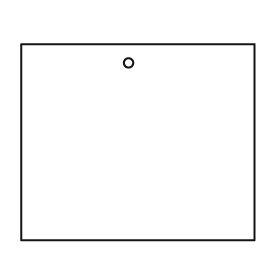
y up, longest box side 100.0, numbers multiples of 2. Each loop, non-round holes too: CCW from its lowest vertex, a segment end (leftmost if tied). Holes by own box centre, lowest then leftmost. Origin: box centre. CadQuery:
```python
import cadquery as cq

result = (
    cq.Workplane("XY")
    .moveTo(-50.0, -42.0)
    .lineTo(50.0, -42.0)
    .lineTo(50.0, 42.0)
    .lineTo(-50.0, 42.0)
    .close()
    .moveTo(-4.0, 34.0)
    .circle(2.0)
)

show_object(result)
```